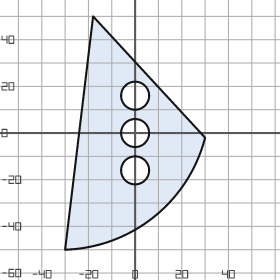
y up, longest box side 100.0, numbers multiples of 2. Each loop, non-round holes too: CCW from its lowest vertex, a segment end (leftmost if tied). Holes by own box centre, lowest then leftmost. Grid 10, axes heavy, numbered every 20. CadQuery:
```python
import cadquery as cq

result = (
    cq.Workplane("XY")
    .moveTo(-30.0, -50.0)
    .threePointArc((8.0, -36.0), (30.0, -2.0))
    .lineTo(-18.0, 50.0)
    .close()
    .moveTo(0.0, -16.0)
    .circle(6.0)
    .moveTo(0.0, 0.0)
    .circle(6.0)
    .moveTo(0.0, 16.0)
    .circle(6.0)
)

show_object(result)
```